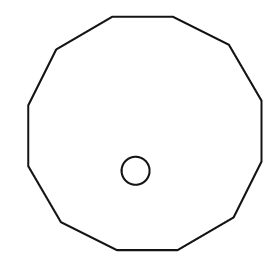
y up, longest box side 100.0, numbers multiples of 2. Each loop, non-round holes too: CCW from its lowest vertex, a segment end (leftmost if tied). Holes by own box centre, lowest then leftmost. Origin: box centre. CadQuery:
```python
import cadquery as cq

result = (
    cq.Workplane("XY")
    .moveTo(-12.0, -50.0)
    .lineTo(14.0, -50.0)
    .lineTo(38.0, -36.0)
    .lineTo(50.0, -12.0)
    .lineTo(50.0, 14.0)
    .lineTo(36.0, 38.0)
    .lineTo(12.0, 50.0)
    .lineTo(-14.0, 50.0)
    .lineTo(-38.0, 36.0)
    .lineTo(-50.0, 12.0)
    .lineTo(-50.0, -14.0)
    .lineTo(-36.0, -38.0)
    .close()
    .moveTo(-4.0, -16.0)
    .circle(6.0)
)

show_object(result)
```